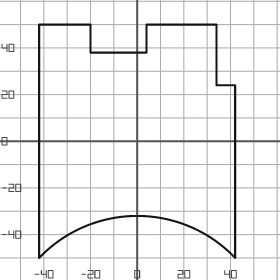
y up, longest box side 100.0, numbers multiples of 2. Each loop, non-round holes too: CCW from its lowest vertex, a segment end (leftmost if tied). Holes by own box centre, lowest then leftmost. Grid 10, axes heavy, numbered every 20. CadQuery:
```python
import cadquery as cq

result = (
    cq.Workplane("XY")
    .moveTo(-42.0, -50.0)
    .threePointArc((0.0, -32.0), (42.0, -50.0))
    .lineTo(42.0, 24.0)
    .lineTo(34.0, 24.0)
    .lineTo(34.0, 50.0)
    .lineTo(4.0, 50.0)
    .lineTo(4.0, 38.0)
    .lineTo(-20.0, 38.0)
    .lineTo(-20.0, 50.0)
    .lineTo(-42.0, 50.0)
    .close()
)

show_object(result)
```